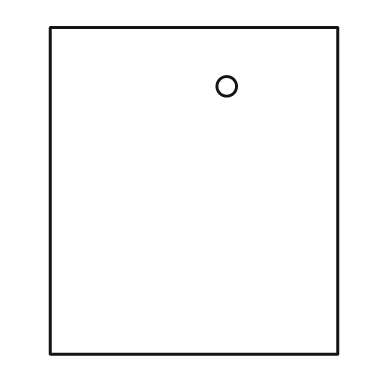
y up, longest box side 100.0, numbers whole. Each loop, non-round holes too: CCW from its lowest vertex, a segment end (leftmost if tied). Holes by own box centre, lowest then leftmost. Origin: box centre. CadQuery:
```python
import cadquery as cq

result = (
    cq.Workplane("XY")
    .moveTo(-44.0, -50.0)
    .lineTo(44.0, -50.0)
    .lineTo(44.0, 50.0)
    .lineTo(-44.0, 50.0)
    .close()
    .moveTo(10.0, 32.0)
    .circle(3.0)
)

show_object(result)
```